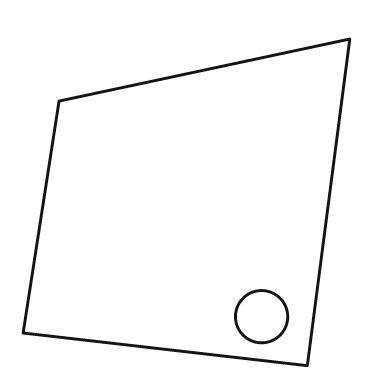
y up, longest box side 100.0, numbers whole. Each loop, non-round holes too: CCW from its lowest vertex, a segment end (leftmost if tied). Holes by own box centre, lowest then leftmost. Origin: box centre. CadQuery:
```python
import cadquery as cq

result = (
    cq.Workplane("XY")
    .moveTo(37.0, -50.0)
    .lineTo(50.0, 50.0)
    .lineTo(-39.0, 31.0)
    .lineTo(-50.0, -40.0)
    .close()
    .moveTo(23.0, -35.0)
    .circle(8.0)
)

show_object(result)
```